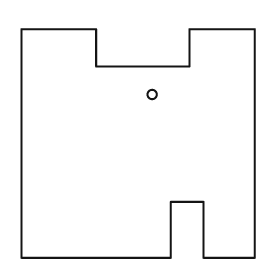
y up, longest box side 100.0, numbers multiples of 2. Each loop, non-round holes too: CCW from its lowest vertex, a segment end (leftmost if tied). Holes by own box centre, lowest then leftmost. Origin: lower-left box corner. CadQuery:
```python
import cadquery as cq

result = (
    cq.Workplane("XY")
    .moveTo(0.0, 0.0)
    .lineTo(64.0, 0.0)
    .lineTo(64.0, 24.0)
    .lineTo(78.0, 24.0)
    .lineTo(78.0, 0.0)
    .lineTo(100.0, 0.0)
    .lineTo(100.0, 98.0)
    .lineTo(72.0, 98.0)
    .lineTo(72.0, 82.0)
    .lineTo(32.0, 82.0)
    .lineTo(32.0, 98.0)
    .lineTo(0.0, 98.0)
    .close()
    .moveTo(56.0, 70.0)
    .circle(2.0)
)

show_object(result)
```